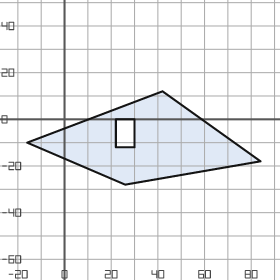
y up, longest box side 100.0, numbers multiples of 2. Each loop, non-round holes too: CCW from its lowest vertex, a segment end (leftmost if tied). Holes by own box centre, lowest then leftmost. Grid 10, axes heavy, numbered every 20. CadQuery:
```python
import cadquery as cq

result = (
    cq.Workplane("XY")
    .moveTo(26.0, -28.0)
    .lineTo(84.0, -18.0)
    .lineTo(42.0, 12.0)
    .lineTo(-16.0, -10.0)
    .close()
    .moveTo(22.0, -12.0)
    .lineTo(30.0, -12.0)
    .lineTo(30.0, 0.0)
    .lineTo(22.0, 0.0)
    .close()
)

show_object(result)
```